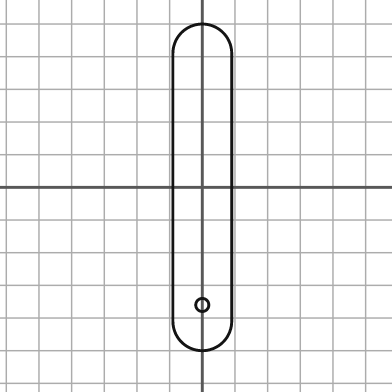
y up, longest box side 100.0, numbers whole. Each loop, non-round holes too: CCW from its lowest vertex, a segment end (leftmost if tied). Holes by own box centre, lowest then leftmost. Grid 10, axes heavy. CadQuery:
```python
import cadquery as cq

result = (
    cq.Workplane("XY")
    .moveTo(-9.0, -41.0)
    .threePointArc((0.0, -50.0), (9.0, -41.0))
    .lineTo(9.0, 41.0)
    .threePointArc((0.0, 50.0), (-9.0, 41.0))
    .close()
    .moveTo(0.0, -36.0)
    .circle(2.0)
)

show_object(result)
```